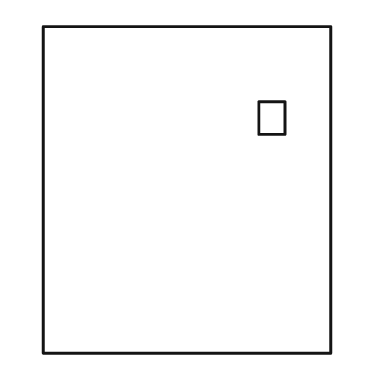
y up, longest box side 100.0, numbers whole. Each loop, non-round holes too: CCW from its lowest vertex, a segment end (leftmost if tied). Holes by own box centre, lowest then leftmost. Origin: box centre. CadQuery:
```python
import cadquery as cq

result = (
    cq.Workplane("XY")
    .moveTo(-44.0, -50.0)
    .lineTo(44.0, -50.0)
    .lineTo(44.0, 50.0)
    .lineTo(-44.0, 50.0)
    .close()
    .moveTo(22.0, 17.0)
    .lineTo(30.0, 17.0)
    .lineTo(30.0, 27.0)
    .lineTo(22.0, 27.0)
    .close()
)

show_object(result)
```